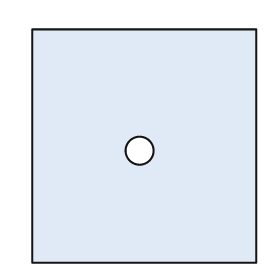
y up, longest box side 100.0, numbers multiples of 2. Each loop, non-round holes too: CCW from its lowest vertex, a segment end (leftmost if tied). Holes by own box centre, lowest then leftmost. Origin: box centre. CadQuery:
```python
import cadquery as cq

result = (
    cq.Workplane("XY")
    .moveTo(-48.0, -50.0)
    .lineTo(48.0, -50.0)
    .lineTo(48.0, 50.0)
    .lineTo(-48.0, 50.0)
    .close()
    .moveTo(-2.0, -2.0)
    .circle(6.0)
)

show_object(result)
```